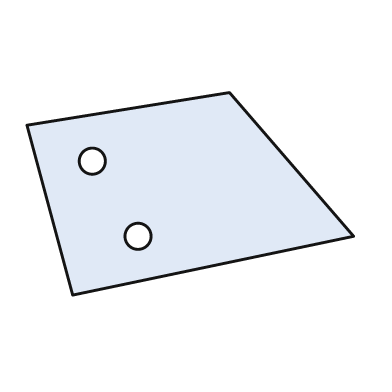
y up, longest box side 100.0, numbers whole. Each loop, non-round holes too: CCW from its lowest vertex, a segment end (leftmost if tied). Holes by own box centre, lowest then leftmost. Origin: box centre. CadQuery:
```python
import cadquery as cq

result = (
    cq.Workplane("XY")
    .moveTo(-36.0, -31.0)
    .lineTo(50.0, -13.0)
    .lineTo(12.0, 31.0)
    .lineTo(-50.0, 21.0)
    .close()
    .moveTo(-16.0, -13.0)
    .circle(4.0)
    .moveTo(-30.0, 10.0)
    .circle(4.0)
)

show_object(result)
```